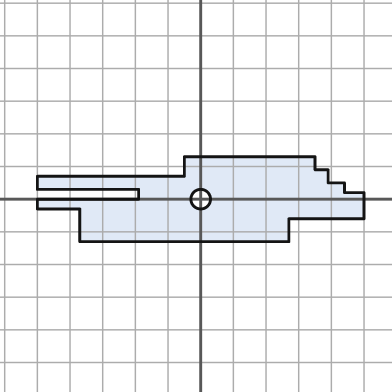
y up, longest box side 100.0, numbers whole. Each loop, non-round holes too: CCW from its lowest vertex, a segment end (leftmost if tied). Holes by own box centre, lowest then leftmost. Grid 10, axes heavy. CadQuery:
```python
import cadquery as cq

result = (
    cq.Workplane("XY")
    .moveTo(-37.0, -13.0)
    .lineTo(27.0, -13.0)
    .lineTo(27.0, -6.0)
    .lineTo(50.0, -6.0)
    .lineTo(50.0, 2.0)
    .lineTo(44.0, 2.0)
    .lineTo(44.0, 5.0)
    .lineTo(39.0, 5.0)
    .lineTo(39.0, 9.0)
    .lineTo(35.0, 9.0)
    .lineTo(35.0, 13.0)
    .lineTo(-5.0, 13.0)
    .lineTo(-5.0, 7.0)
    .lineTo(-50.0, 7.0)
    .lineTo(-50.0, 3.0)
    .lineTo(-19.0, 3.0)
    .lineTo(-19.0, 0.0)
    .lineTo(-50.0, 0.0)
    .lineTo(-50.0, -3.0)
    .lineTo(-37.0, -3.0)
    .close()
    .moveTo(0.0, 0.0)
    .circle(3.0)
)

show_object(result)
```